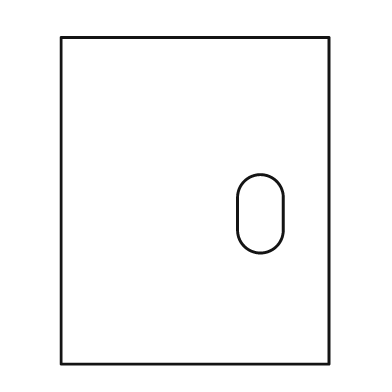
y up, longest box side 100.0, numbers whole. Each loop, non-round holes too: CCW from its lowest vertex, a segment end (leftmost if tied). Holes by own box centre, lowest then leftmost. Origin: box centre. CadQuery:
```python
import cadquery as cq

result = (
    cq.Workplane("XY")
    .moveTo(-41.0, -50.0)
    .lineTo(41.0, -50.0)
    .lineTo(41.0, 50.0)
    .lineTo(-41.0, 50.0)
    .close()
    .moveTo(13.0, -9.0)
    .threePointArc((20.0, -16.0), (27.0, -9.0))
    .lineTo(27.0, 1.0)
    .threePointArc((20.0, 8.0), (13.0, 1.0))
    .close()
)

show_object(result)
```